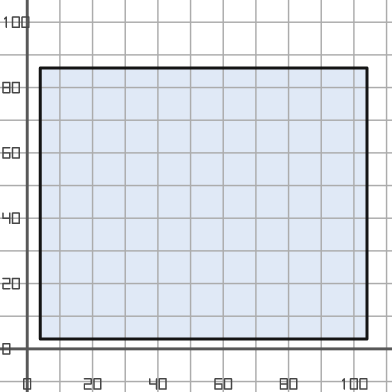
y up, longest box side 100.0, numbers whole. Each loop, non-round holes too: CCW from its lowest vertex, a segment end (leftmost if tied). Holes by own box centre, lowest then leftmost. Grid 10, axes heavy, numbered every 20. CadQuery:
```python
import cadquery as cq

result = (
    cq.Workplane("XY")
    .moveTo(4.0, 3.0)
    .lineTo(104.0, 3.0)
    .lineTo(104.0, 86.0)
    .lineTo(4.0, 86.0)
    .close()
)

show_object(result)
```